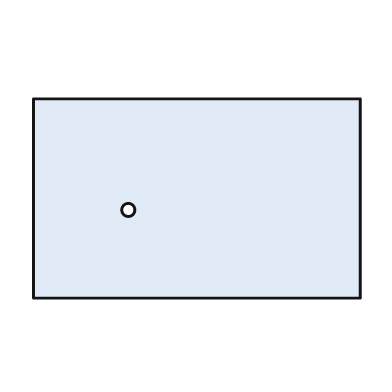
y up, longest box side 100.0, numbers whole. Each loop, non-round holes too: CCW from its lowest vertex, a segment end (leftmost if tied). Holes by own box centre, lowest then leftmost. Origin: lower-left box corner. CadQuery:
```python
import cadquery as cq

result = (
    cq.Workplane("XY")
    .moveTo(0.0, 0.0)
    .lineTo(100.0, 0.0)
    .lineTo(100.0, 61.0)
    .lineTo(0.0, 61.0)
    .close()
    .moveTo(29.0, 27.0)
    .circle(2.0)
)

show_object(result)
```